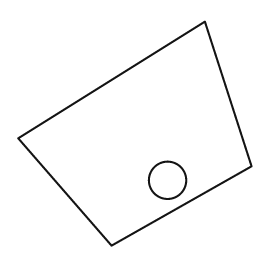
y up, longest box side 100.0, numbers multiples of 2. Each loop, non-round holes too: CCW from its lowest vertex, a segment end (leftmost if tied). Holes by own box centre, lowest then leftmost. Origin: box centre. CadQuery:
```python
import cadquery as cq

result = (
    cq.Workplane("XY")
    .moveTo(-10.0, -48.0)
    .lineTo(50.0, -14.0)
    .lineTo(30.0, 48.0)
    .lineTo(-50.0, -2.0)
    .close()
    .moveTo(14.0, -20.0)
    .circle(8.0)
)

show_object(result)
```